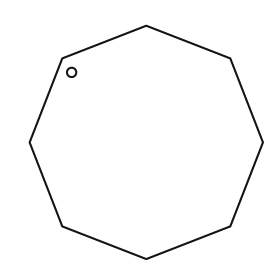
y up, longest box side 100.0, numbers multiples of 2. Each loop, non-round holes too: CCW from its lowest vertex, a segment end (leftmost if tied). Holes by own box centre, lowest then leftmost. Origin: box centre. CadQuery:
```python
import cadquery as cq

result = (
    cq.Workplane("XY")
    .moveTo(0.0, -50.0)
    .lineTo(36.0, -36.0)
    .lineTo(50.0, 0.0)
    .lineTo(36.0, 36.0)
    .lineTo(0.0, 50.0)
    .lineTo(-36.0, 36.0)
    .lineTo(-50.0, 0.0)
    .lineTo(-36.0, -36.0)
    .close()
    .moveTo(-32.0, 30.0)
    .circle(2.0)
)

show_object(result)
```